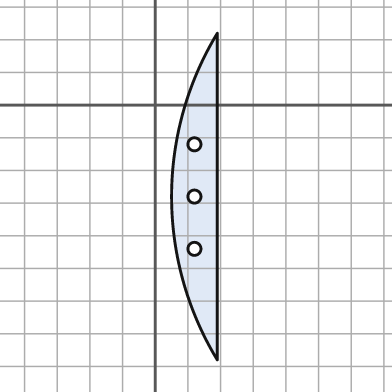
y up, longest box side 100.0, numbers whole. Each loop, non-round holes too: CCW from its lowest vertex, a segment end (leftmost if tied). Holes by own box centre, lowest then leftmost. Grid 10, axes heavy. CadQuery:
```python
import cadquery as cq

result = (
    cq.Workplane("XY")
    .moveTo(19.0, -78.0)
    .lineTo(19.0, 22.0)
    .threePointArc((5.0, -28.0), (19.0, -78.0))
    .close()
    .moveTo(12.0, -44.0)
    .circle(2.0)
    .moveTo(12.0, -28.0)
    .circle(2.0)
    .moveTo(12.0, -12.0)
    .circle(2.0)
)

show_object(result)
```